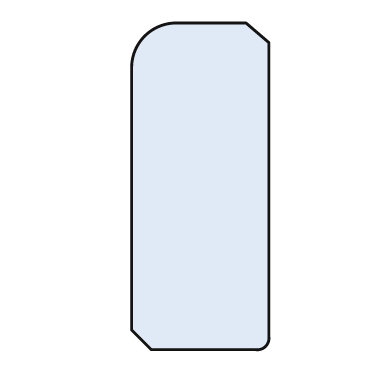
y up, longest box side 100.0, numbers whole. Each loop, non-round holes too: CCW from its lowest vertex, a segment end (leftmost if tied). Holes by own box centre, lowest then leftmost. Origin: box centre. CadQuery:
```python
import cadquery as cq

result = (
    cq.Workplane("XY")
    .moveTo(-15.0, -50.0)
    .lineTo(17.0, -50.0)
    .threePointArc((20.0, -49.0), (21.0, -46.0))
    .lineTo(21.0, 44.0)
    .lineTo(14.0, 50.0)
    .lineTo(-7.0, 50.0)
    .threePointArc((-17.0, 46.0), (-21.0, 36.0))
    .lineTo(-21.0, -44.0)
    .close()
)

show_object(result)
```